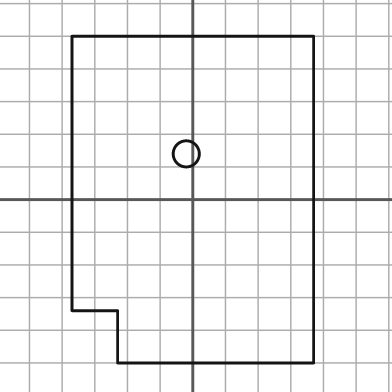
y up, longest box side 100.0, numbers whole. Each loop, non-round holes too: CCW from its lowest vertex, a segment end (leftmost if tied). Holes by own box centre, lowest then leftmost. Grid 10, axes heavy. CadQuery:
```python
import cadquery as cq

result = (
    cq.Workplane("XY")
    .moveTo(-23.0, -50.0)
    .lineTo(37.0, -50.0)
    .lineTo(37.0, 50.0)
    .lineTo(-37.0, 50.0)
    .lineTo(-37.0, -34.0)
    .lineTo(-23.0, -34.0)
    .close()
    .moveTo(-2.0, 14.0)
    .circle(4.0)
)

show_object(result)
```